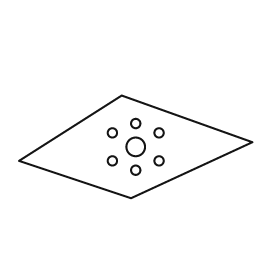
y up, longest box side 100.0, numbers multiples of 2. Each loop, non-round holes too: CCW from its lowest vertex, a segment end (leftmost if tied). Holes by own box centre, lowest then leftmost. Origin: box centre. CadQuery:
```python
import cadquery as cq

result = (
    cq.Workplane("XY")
    .moveTo(-2.0, -22.0)
    .lineTo(50.0, 2.0)
    .lineTo(-6.0, 22.0)
    .lineTo(-50.0, -6.0)
    .close()
    .moveTo(0.0, -10.0)
    .circle(2.0)
    .moveTo(-10.0, -6.0)
    .circle(2.0)
    .moveTo(10.0, -6.0)
    .circle(2.0)
    .moveTo(0.0, 0.0)
    .circle(4.0)
    .moveTo(-10.0, 6.0)
    .circle(2.0)
    .moveTo(10.0, 6.0)
    .circle(2.0)
    .moveTo(0.0, 10.0)
    .circle(2.0)
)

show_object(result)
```